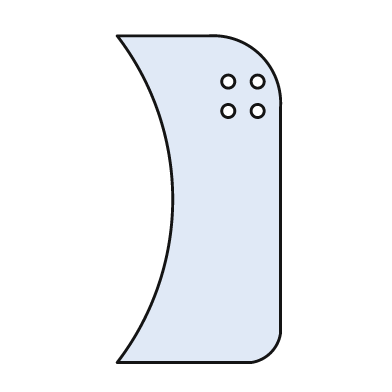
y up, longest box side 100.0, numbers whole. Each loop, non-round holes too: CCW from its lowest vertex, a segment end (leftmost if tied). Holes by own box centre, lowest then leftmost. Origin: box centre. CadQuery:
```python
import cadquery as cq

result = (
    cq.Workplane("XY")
    .moveTo(-25.0, -50.0)
    .lineTo(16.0, -50.0)
    .threePointArc((22.0, -47.0), (25.0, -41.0))
    .lineTo(25.0, 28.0)
    .threePointArc((19.0, 44.0), (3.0, 50.0))
    .lineTo(-25.0, 50.0)
    .threePointArc((-8.0, 0.0), (-25.0, -50.0))
    .close()
    .moveTo(9.0, 27.0)
    .circle(2.0)
    .moveTo(18.0, 27.0)
    .circle(2.0)
    .moveTo(9.0, 36.0)
    .circle(2.0)
    .moveTo(18.0, 36.0)
    .circle(2.0)
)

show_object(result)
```